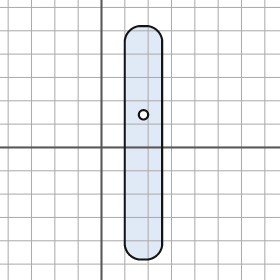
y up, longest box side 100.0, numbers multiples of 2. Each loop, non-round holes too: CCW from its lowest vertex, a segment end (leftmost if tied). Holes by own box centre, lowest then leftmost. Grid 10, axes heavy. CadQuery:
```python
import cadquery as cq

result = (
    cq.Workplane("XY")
    .moveTo(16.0, -48.0)
    .lineTo(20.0, -48.0)
    .threePointArc((24.0, -46.0), (26.0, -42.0))
    .lineTo(26.0, 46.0)
    .threePointArc((24.0, 50.0), (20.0, 52.0))
    .lineTo(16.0, 52.0)
    .threePointArc((12.0, 50.0), (10.0, 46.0))
    .lineTo(10.0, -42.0)
    .threePointArc((12.0, -46.0), (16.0, -48.0))
    .close()
    .moveTo(18.0, 14.0)
    .circle(2.0)
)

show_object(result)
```